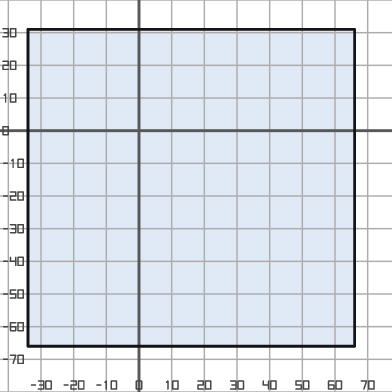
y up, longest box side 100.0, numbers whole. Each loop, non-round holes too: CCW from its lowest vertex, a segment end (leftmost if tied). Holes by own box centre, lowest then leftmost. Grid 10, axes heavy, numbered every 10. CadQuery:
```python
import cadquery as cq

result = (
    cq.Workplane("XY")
    .moveTo(-34.0, -66.0)
    .lineTo(66.0, -66.0)
    .lineTo(66.0, 31.0)
    .lineTo(-34.0, 31.0)
    .close()
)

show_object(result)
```